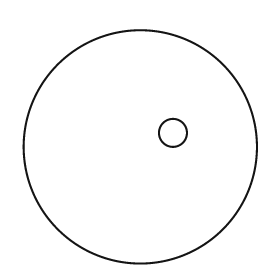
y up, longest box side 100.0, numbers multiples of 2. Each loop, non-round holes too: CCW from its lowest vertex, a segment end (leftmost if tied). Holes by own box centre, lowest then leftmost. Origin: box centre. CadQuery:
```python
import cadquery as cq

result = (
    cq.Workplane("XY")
    .moveTo(0.0, 0.0)
    .circle(50.0)
    .moveTo(14.0, 6.0)
    .circle(6.0)
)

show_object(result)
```